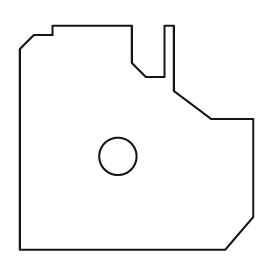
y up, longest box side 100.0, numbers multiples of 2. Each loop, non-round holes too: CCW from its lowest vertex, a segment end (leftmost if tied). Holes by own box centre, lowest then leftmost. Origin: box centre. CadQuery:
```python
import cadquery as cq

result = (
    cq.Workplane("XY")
    .moveTo(-50.0, -48.0)
    .lineTo(38.0, -48.0)
    .lineTo(50.0, -34.0)
    .lineTo(50.0, 8.0)
    .lineTo(32.0, 8.0)
    .lineTo(16.0, 20.0)
    .lineTo(16.0, 48.0)
    .lineTo(12.0, 48.0)
    .lineTo(12.0, 26.0)
    .lineTo(4.0, 26.0)
    .lineTo(-2.0, 32.0)
    .lineTo(-2.0, 48.0)
    .lineTo(-36.0, 48.0)
    .lineTo(-36.0, 44.0)
    .lineTo(-44.0, 44.0)
    .lineTo(-50.0, 38.0)
    .close()
    .moveTo(-8.0, -8.0)
    .circle(8.0)
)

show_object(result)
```